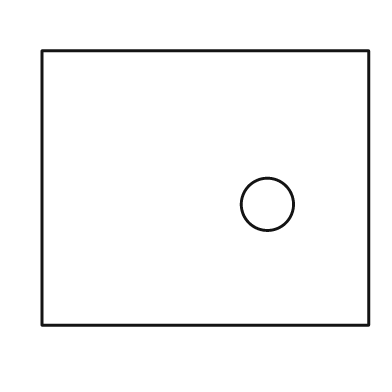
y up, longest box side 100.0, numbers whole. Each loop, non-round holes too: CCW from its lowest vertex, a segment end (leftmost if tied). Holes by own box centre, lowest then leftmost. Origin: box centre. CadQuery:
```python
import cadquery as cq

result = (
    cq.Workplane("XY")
    .moveTo(-50.0, -42.0)
    .lineTo(50.0, -42.0)
    .lineTo(50.0, 42.0)
    .lineTo(-50.0, 42.0)
    .close()
    .moveTo(19.0, -5.0)
    .circle(8.0)
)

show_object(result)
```